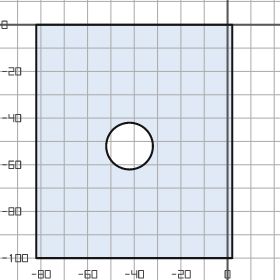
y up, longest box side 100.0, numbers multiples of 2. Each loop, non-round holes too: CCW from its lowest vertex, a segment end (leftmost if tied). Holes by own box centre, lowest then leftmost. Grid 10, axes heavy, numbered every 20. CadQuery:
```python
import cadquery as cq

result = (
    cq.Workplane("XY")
    .moveTo(-82.0, -100.0)
    .lineTo(2.0, -100.0)
    .lineTo(2.0, 0.0)
    .lineTo(-82.0, 0.0)
    .close()
    .moveTo(-42.0, -52.0)
    .circle(10.0)
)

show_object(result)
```